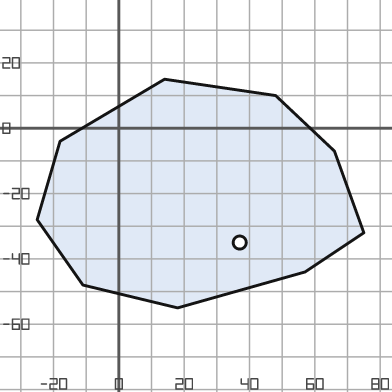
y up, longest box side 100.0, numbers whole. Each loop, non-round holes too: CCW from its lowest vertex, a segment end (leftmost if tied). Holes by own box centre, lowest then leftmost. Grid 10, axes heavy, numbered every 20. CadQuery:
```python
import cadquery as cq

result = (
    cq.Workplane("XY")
    .moveTo(18.0, -55.0)
    .lineTo(57.0, -44.0)
    .lineTo(75.0, -32.0)
    .lineTo(66.0, -7.0)
    .lineTo(48.0, 10.0)
    .lineTo(14.0, 15.0)
    .lineTo(-18.0, -4.0)
    .lineTo(-25.0, -28.0)
    .lineTo(-11.0, -48.0)
    .close()
    .moveTo(37.0, -35.0)
    .circle(2.0)
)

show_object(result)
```